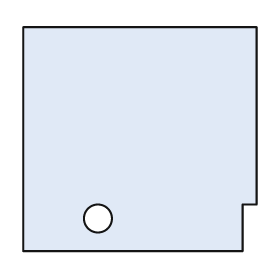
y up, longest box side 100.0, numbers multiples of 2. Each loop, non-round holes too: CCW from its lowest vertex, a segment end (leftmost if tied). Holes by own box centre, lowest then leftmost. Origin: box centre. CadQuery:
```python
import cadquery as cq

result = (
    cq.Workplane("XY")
    .moveTo(-50.0, -48.0)
    .lineTo(44.0, -48.0)
    .lineTo(44.0, -28.0)
    .lineTo(50.0, -28.0)
    .lineTo(50.0, 48.0)
    .lineTo(-50.0, 48.0)
    .close()
    .moveTo(-18.0, -34.0)
    .circle(6.0)
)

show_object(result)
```